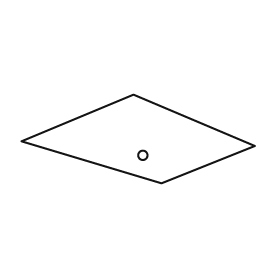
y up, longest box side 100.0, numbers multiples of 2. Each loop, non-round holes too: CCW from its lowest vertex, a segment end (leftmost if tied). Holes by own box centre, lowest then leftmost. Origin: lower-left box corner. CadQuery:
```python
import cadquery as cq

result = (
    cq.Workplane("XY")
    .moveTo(60.0, 0.0)
    .lineTo(100.0, 16.0)
    .lineTo(48.0, 38.0)
    .lineTo(0.0, 18.0)
    .close()
    .moveTo(52.0, 12.0)
    .circle(2.0)
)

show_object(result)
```